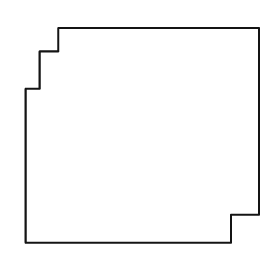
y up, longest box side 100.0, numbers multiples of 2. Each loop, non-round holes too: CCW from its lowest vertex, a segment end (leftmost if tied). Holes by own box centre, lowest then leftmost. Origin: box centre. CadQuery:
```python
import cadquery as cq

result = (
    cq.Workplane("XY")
    .moveTo(-50.0, -46.0)
    .lineTo(38.0, -46.0)
    .lineTo(38.0, -34.0)
    .lineTo(50.0, -34.0)
    .lineTo(50.0, 46.0)
    .lineTo(-36.0, 46.0)
    .lineTo(-36.0, 36.0)
    .lineTo(-44.0, 36.0)
    .lineTo(-44.0, 20.0)
    .lineTo(-50.0, 20.0)
    .close()
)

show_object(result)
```